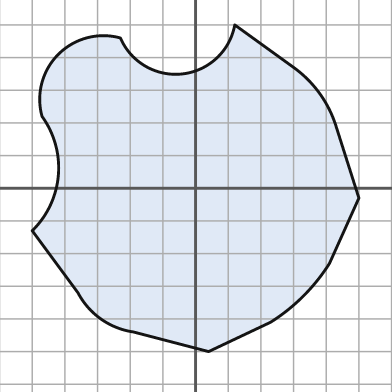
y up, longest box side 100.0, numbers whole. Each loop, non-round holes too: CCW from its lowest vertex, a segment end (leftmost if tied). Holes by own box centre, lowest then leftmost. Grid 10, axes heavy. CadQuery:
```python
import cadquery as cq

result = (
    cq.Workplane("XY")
    .moveTo(4.0, -50.0)
    .lineTo(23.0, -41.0)
    .threePointArc((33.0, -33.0), (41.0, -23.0))
    .lineTo(50.0, -3.0)
    .lineTo(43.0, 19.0)
    .threePointArc((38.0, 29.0), (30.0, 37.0))
    .lineTo(12.0, 50.0)
    .threePointArc((-4.0, 35.0), (-23.0, 46.0))
    .threePointArc((-42.0, 41.0), (-47.0, 22.0))
    .threePointArc((-42.0, 4.0), (-50.0, -13.0))
    .lineTo(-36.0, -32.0)
    .threePointArc((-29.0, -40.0), (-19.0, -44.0))
    .close()
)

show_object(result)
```